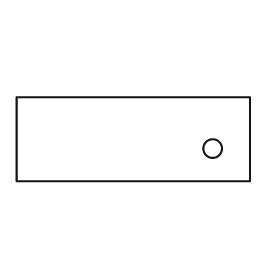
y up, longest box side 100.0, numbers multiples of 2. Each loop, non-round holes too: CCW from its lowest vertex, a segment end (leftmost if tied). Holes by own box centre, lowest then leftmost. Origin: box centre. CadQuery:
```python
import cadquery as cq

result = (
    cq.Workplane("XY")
    .moveTo(-50.0, -18.0)
    .lineTo(50.0, -18.0)
    .lineTo(50.0, 18.0)
    .lineTo(-50.0, 18.0)
    .close()
    .moveTo(34.0, -4.0)
    .circle(4.0)
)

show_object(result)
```